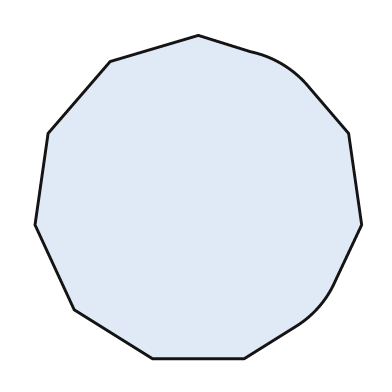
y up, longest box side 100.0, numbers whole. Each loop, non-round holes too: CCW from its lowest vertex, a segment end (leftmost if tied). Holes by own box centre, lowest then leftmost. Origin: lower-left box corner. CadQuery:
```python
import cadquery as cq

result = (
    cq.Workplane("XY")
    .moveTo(36.0, 0.0)
    .lineTo(64.0, 0.0)
    .lineTo(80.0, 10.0)
    .threePointArc((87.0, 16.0), (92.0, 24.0))
    .lineTo(100.0, 41.0)
    .lineTo(96.0, 69.0)
    .lineTo(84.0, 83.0)
    .threePointArc((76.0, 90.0), (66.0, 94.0))
    .lineTo(50.0, 99.0)
    .lineTo(23.0, 91.0)
    .lineTo(4.0, 69.0)
    .lineTo(0.0, 41.0)
    .lineTo(12.0, 15.0)
    .close()
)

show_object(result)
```